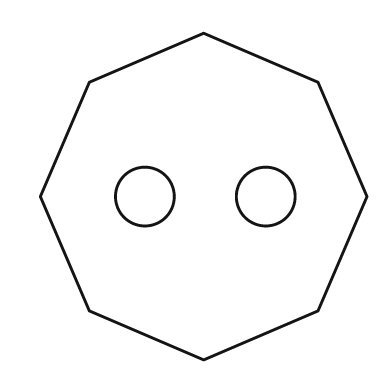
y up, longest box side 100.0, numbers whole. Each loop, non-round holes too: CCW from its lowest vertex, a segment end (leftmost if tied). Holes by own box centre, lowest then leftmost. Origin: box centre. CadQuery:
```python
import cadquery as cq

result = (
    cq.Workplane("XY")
    .moveTo(0.0, -50.0)
    .lineTo(35.0, -35.0)
    .lineTo(50.0, 0.0)
    .lineTo(35.0, 35.0)
    .lineTo(0.0, 50.0)
    .lineTo(-35.0, 35.0)
    .lineTo(-50.0, 0.0)
    .lineTo(-35.0, -35.0)
    .close()
    .moveTo(-18.0, 0.0)
    .circle(9.0)
    .moveTo(19.0, 0.0)
    .circle(9.0)
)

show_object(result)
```